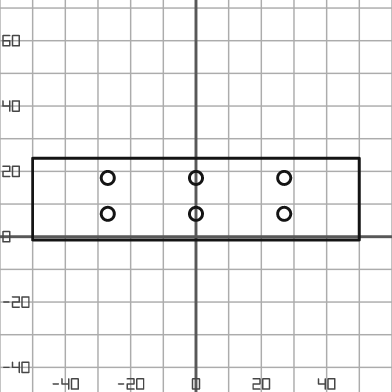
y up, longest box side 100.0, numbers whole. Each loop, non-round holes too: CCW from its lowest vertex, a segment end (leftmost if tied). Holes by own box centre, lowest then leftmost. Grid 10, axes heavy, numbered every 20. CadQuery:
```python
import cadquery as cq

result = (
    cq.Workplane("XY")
    .moveTo(-50.0, -1.0)
    .lineTo(50.0, -1.0)
    .lineTo(50.0, 24.0)
    .lineTo(-50.0, 24.0)
    .close()
    .moveTo(-27.0, 7.0)
    .circle(2.0)
    .moveTo(0.0, 7.0)
    .circle(2.0)
    .moveTo(27.0, 7.0)
    .circle(2.0)
    .moveTo(-27.0, 18.0)
    .circle(2.0)
    .moveTo(0.0, 18.0)
    .circle(2.0)
    .moveTo(27.0, 18.0)
    .circle(2.0)
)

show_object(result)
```